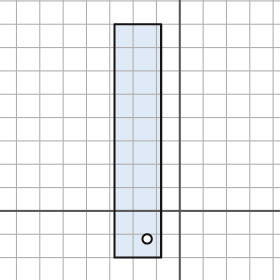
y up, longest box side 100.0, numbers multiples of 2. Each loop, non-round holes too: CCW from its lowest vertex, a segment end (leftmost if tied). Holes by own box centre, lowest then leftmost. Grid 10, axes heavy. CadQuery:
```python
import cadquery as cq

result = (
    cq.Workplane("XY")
    .moveTo(-28.0, -20.0)
    .lineTo(-8.0, -20.0)
    .lineTo(-8.0, 80.0)
    .lineTo(-28.0, 80.0)
    .close()
    .moveTo(-14.0, -12.0)
    .circle(2.0)
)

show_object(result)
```